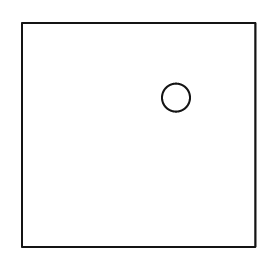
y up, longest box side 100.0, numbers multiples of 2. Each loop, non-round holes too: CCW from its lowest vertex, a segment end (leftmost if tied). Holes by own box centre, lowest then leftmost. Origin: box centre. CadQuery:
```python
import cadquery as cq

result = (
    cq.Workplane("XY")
    .moveTo(-50.0, -48.0)
    .lineTo(50.0, -48.0)
    .lineTo(50.0, 48.0)
    .lineTo(-50.0, 48.0)
    .close()
    .moveTo(16.0, 16.0)
    .circle(6.0)
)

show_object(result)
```